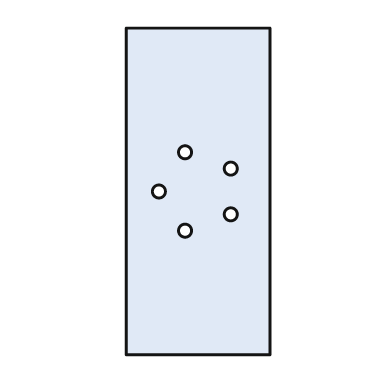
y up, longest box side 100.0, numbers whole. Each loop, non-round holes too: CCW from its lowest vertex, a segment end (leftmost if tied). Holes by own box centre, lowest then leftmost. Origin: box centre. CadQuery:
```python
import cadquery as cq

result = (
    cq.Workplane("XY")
    .moveTo(-22.0, -50.0)
    .lineTo(22.0, -50.0)
    .lineTo(22.0, 50.0)
    .lineTo(-22.0, 50.0)
    .close()
    .moveTo(-4.0, -12.0)
    .circle(2.0)
    .moveTo(10.0, -7.0)
    .circle(2.0)
    .moveTo(-12.0, 0.0)
    .circle(2.0)
    .moveTo(10.0, 7.0)
    .circle(2.0)
    .moveTo(-4.0, 12.0)
    .circle(2.0)
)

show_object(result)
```